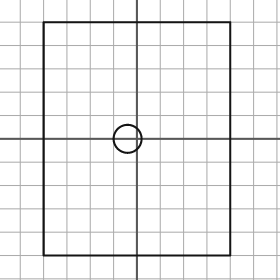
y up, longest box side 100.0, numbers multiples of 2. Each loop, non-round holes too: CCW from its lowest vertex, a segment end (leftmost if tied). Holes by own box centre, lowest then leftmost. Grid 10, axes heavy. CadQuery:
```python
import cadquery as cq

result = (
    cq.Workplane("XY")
    .moveTo(-40.0, -50.0)
    .lineTo(40.0, -50.0)
    .lineTo(40.0, 50.0)
    .lineTo(-40.0, 50.0)
    .close()
    .moveTo(-4.0, 0.0)
    .circle(6.0)
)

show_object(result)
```